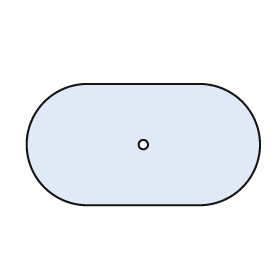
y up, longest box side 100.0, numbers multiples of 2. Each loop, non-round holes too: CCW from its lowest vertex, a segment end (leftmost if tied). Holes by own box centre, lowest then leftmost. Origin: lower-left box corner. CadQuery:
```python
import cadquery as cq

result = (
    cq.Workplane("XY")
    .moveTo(26.0, 0.0)
    .lineTo(74.0, 0.0)
    .threePointArc((100.0, 26.0), (74.0, 52.0))
    .lineTo(26.0, 52.0)
    .threePointArc((0.0, 26.0), (26.0, 0.0))
    .close()
    .moveTo(50.0, 26.0)
    .circle(2.0)
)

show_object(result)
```